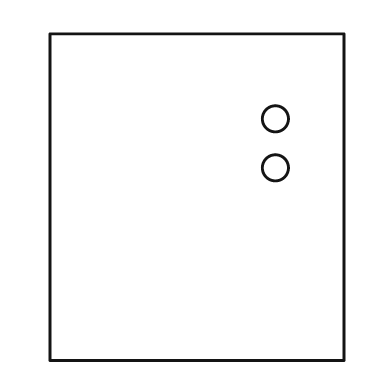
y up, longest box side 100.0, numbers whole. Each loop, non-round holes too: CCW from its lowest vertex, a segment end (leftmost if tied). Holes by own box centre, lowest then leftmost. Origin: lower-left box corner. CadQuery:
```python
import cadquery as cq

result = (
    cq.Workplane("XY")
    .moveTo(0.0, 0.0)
    .lineTo(90.0, 0.0)
    .lineTo(90.0, 100.0)
    .lineTo(0.0, 100.0)
    .close()
    .moveTo(69.0, 59.0)
    .circle(4.0)
    .moveTo(69.0, 74.0)
    .circle(4.0)
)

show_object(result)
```